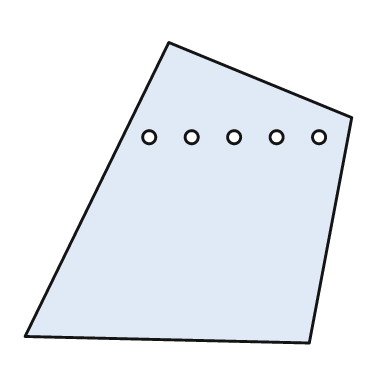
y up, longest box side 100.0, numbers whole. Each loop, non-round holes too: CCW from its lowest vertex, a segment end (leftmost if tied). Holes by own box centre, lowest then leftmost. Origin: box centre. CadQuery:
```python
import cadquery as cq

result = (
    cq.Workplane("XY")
    .moveTo(37.0, -46.0)
    .lineTo(50.0, 23.0)
    .lineTo(-6.0, 46.0)
    .lineTo(-50.0, -44.0)
    .close()
    .moveTo(-12.0, 17.0)
    .circle(2.0)
    .moveTo(1.0, 17.0)
    .circle(2.0)
    .moveTo(14.0, 17.0)
    .circle(2.0)
    .moveTo(27.0, 17.0)
    .circle(2.0)
    .moveTo(40.0, 17.0)
    .circle(2.0)
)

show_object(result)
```